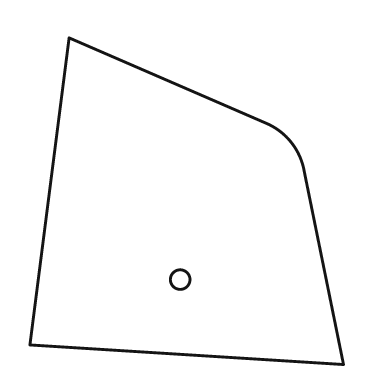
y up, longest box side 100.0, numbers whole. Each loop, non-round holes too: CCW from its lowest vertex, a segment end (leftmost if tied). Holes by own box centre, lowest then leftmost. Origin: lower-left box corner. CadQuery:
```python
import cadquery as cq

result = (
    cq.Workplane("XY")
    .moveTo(96.0, 0.0)
    .lineTo(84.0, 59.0)
    .threePointArc((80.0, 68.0), (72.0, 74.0))
    .lineTo(12.0, 100.0)
    .lineTo(0.0, 6.0)
    .close()
    .moveTo(46.0, 26.0)
    .circle(3.0)
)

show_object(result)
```